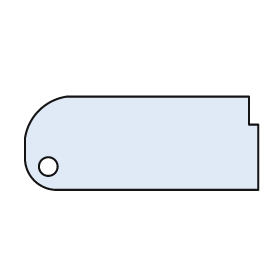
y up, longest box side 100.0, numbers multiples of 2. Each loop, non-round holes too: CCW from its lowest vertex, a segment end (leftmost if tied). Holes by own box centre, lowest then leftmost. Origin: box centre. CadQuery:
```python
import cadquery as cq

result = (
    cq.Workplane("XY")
    .moveTo(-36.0, -20.0)
    .lineTo(50.0, -20.0)
    .lineTo(50.0, 8.0)
    .lineTo(46.0, 8.0)
    .lineTo(46.0, 20.0)
    .lineTo(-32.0, 20.0)
    .threePointArc((-44.0, 14.0), (-50.0, 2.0))
    .lineTo(-50.0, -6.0)
    .threePointArc((-46.0, -16.0), (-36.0, -20.0))
    .close()
    .moveTo(-40.0, -10.0)
    .circle(4.0)
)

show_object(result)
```